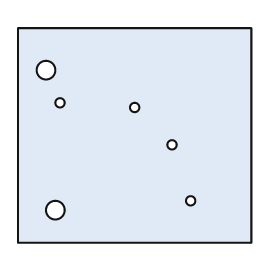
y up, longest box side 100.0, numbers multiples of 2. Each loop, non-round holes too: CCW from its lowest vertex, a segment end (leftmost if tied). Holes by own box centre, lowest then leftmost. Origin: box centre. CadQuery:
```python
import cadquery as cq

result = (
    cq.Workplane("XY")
    .moveTo(-50.0, -46.0)
    .lineTo(50.0, -46.0)
    .lineTo(50.0, 46.0)
    .lineTo(-50.0, 46.0)
    .close()
    .moveTo(-34.0, -32.0)
    .circle(4.0)
    .moveTo(24.0, -28.0)
    .circle(2.0)
    .moveTo(16.0, -4.0)
    .circle(2.0)
    .moveTo(0.0, 12.0)
    .circle(2.0)
    .moveTo(-32.0, 14.0)
    .circle(2.0)
    .moveTo(-38.0, 28.0)
    .circle(4.0)
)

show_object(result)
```